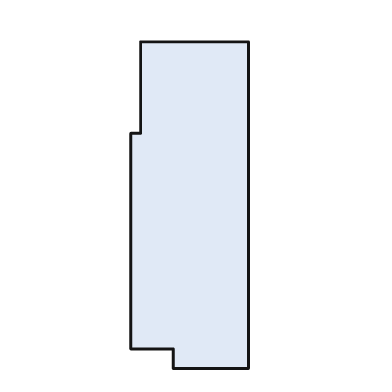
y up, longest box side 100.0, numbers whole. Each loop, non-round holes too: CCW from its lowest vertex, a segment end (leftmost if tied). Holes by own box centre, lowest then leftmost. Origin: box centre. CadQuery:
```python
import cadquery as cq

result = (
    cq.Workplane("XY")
    .moveTo(-5.0, -50.0)
    .lineTo(18.0, -50.0)
    .lineTo(18.0, 50.0)
    .lineTo(-15.0, 50.0)
    .lineTo(-15.0, 22.0)
    .lineTo(-18.0, 22.0)
    .lineTo(-18.0, -44.0)
    .lineTo(-5.0, -44.0)
    .close()
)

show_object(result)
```